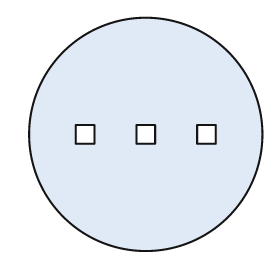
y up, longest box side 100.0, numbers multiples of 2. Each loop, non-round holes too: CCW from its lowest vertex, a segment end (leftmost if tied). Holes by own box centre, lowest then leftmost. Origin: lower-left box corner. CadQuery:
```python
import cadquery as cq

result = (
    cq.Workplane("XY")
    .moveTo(50.0, 50.0)
    .circle(50.0)
    .moveTo(20.0, 46.0)
    .lineTo(28.0, 46.0)
    .lineTo(28.0, 54.0)
    .lineTo(20.0, 54.0)
    .close()
    .moveTo(46.0, 46.0)
    .lineTo(54.0, 46.0)
    .lineTo(54.0, 54.0)
    .lineTo(46.0, 54.0)
    .close()
    .moveTo(72.0, 46.0)
    .lineTo(80.0, 46.0)
    .lineTo(80.0, 54.0)
    .lineTo(72.0, 54.0)
    .close()
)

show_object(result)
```